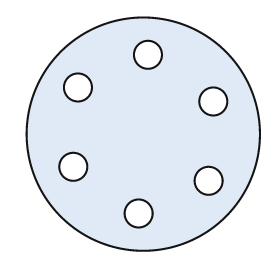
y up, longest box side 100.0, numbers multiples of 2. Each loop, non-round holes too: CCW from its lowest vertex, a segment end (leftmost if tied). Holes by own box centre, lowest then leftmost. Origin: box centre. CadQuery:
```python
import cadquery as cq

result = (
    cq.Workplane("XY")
    .moveTo(0.0, 0.0)
    .circle(50.0)
    .moveTo(-2.0, -34.0)
    .circle(6.0)
    .moveTo(28.0, -20.0)
    .circle(6.0)
    .moveTo(-30.0, -14.0)
    .circle(6.0)
    .moveTo(30.0, 14.0)
    .circle(6.0)
    .moveTo(-28.0, 20.0)
    .circle(6.0)
    .moveTo(2.0, 34.0)
    .circle(6.0)
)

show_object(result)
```